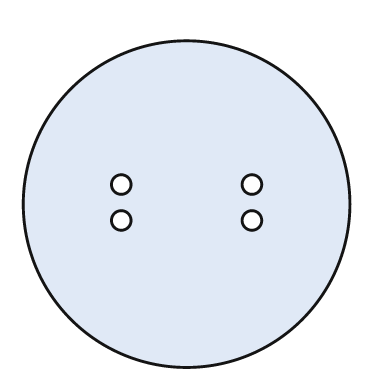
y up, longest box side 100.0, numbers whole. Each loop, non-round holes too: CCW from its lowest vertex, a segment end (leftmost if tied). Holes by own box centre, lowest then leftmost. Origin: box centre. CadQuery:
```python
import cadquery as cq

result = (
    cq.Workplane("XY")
    .moveTo(0.0, 0.0)
    .circle(50.0)
    .moveTo(-20.0, -5.0)
    .circle(3.0)
    .moveTo(20.0, -5.0)
    .circle(3.0)
    .moveTo(-20.0, 6.0)
    .circle(3.0)
    .moveTo(20.0, 6.0)
    .circle(3.0)
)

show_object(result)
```